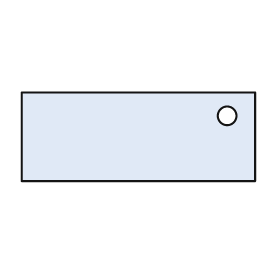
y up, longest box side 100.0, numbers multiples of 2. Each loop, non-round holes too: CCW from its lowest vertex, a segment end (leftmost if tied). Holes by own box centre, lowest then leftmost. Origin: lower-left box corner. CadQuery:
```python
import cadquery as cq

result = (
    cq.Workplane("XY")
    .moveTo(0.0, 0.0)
    .lineTo(100.0, 0.0)
    .lineTo(100.0, 38.0)
    .lineTo(0.0, 38.0)
    .close()
    .moveTo(88.0, 28.0)
    .circle(4.0)
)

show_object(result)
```